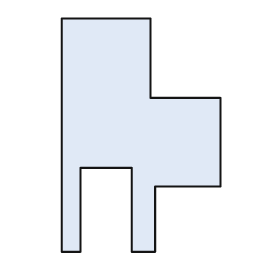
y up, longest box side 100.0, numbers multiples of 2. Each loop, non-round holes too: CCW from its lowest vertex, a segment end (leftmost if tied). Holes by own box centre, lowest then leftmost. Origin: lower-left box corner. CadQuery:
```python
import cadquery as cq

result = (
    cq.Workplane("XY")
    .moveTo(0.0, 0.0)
    .lineTo(8.0, 0.0)
    .lineTo(8.0, 36.0)
    .lineTo(30.0, 36.0)
    .lineTo(30.0, 0.0)
    .lineTo(40.0, 0.0)
    .lineTo(40.0, 28.0)
    .lineTo(68.0, 28.0)
    .lineTo(68.0, 66.0)
    .lineTo(38.0, 66.0)
    .lineTo(38.0, 100.0)
    .lineTo(0.0, 100.0)
    .close()
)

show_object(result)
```